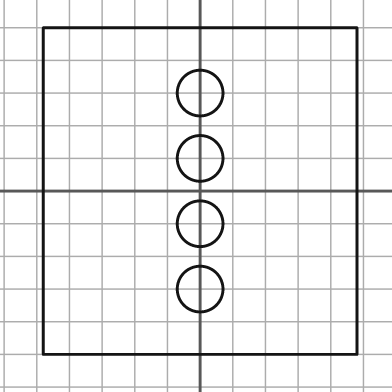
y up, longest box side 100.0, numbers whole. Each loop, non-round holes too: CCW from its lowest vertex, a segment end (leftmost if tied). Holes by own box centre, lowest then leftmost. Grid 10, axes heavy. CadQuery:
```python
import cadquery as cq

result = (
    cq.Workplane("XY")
    .moveTo(-48.0, -50.0)
    .lineTo(48.0, -50.0)
    .lineTo(48.0, 50.0)
    .lineTo(-48.0, 50.0)
    .close()
    .moveTo(0.0, -30.0)
    .circle(7.0)
    .moveTo(0.0, -10.0)
    .circle(7.0)
    .moveTo(0.0, 10.0)
    .circle(7.0)
    .moveTo(0.0, 30.0)
    .circle(7.0)
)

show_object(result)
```